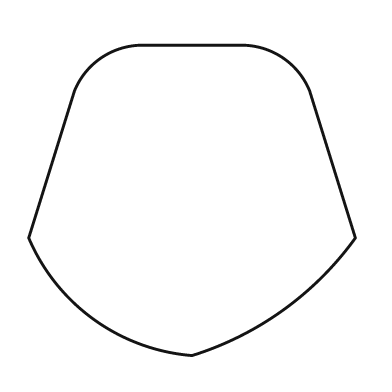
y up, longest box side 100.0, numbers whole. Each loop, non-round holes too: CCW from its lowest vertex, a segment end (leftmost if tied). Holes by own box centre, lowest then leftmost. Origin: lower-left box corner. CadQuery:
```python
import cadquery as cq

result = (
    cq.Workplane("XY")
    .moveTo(50.0, 0.0)
    .threePointArc((78.0, 14.0), (100.0, 36.0))
    .lineTo(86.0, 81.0)
    .threePointArc((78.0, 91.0), (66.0, 95.0))
    .lineTo(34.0, 95.0)
    .threePointArc((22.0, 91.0), (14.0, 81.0))
    .lineTo(0.0, 36.0)
    .threePointArc((20.0, 11.0), (50.0, 0.0))
    .close()
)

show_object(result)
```